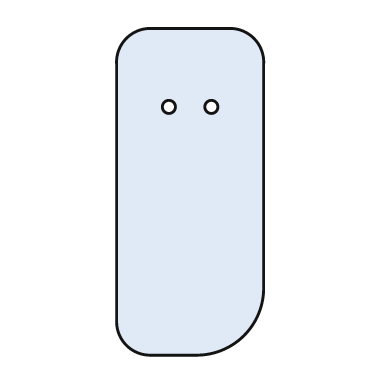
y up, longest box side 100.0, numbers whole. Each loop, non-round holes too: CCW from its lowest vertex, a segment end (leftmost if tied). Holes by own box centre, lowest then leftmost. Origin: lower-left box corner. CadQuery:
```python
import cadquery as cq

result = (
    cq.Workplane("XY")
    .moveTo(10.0, 0.0)
    .lineTo(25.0, 0.0)
    .threePointArc((39.0, 6.0), (45.0, 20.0))
    .lineTo(45.0, 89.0)
    .threePointArc((42.0, 97.0), (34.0, 100.0))
    .lineTo(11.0, 100.0)
    .threePointArc((3.0, 97.0), (0.0, 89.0))
    .lineTo(0.0, 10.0)
    .threePointArc((3.0, 3.0), (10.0, 0.0))
    .close()
    .moveTo(16.0, 76.0)
    .circle(2.0)
    .moveTo(29.0, 76.0)
    .circle(2.0)
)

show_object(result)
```